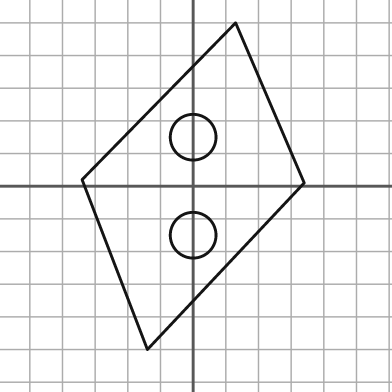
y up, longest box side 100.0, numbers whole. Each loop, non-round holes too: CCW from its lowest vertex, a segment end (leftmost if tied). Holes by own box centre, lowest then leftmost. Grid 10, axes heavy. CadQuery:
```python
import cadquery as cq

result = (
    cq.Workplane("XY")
    .moveTo(-14.0, -50.0)
    .lineTo(34.0, 1.0)
    .lineTo(13.0, 50.0)
    .lineTo(-34.0, 2.0)
    .close()
    .moveTo(0.0, -15.0)
    .circle(7.0)
    .moveTo(0.0, 15.0)
    .circle(7.0)
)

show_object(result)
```